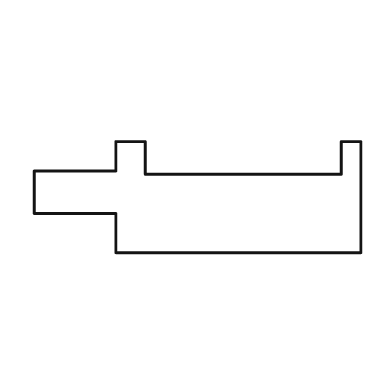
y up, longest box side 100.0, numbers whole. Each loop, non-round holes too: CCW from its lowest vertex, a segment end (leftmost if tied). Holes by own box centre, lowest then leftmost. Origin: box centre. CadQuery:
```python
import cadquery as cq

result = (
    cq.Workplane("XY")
    .moveTo(-25.0, -17.0)
    .lineTo(50.0, -17.0)
    .lineTo(50.0, 17.0)
    .lineTo(44.0, 17.0)
    .lineTo(44.0, 7.0)
    .lineTo(-16.0, 7.0)
    .lineTo(-16.0, 17.0)
    .lineTo(-25.0, 17.0)
    .lineTo(-25.0, 8.0)
    .lineTo(-50.0, 8.0)
    .lineTo(-50.0, -5.0)
    .lineTo(-25.0, -5.0)
    .close()
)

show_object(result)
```